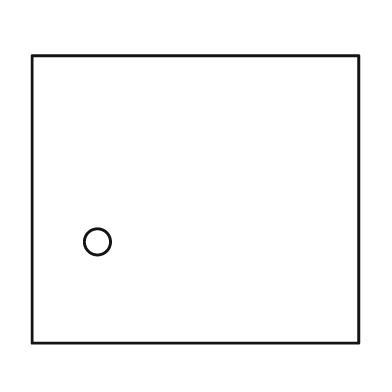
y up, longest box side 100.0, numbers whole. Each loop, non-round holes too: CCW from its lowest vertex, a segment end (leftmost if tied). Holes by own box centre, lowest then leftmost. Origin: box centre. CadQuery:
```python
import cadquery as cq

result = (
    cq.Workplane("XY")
    .moveTo(-50.0, -44.0)
    .lineTo(50.0, -44.0)
    .lineTo(50.0, 44.0)
    .lineTo(-50.0, 44.0)
    .close()
    .moveTo(-30.0, -13.0)
    .circle(4.0)
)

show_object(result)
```